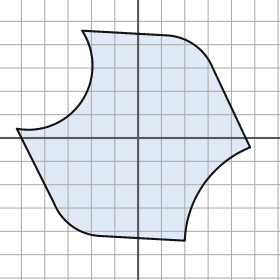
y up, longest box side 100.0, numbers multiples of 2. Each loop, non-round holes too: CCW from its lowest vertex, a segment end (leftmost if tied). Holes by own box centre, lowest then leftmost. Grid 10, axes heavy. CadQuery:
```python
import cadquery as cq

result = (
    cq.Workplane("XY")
    .moveTo(20.0, -44.0)
    .threePointArc((28.0, -20.0), (48.0, -4.0))
    .lineTo(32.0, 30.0)
    .threePointArc((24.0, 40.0), (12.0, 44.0))
    .lineTo(-24.0, 46.0)
    .threePointArc((-24.0, 16.0), (-52.0, 4.0))
    .lineTo(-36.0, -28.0)
    .threePointArc((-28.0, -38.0), (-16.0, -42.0))
    .close()
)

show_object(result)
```